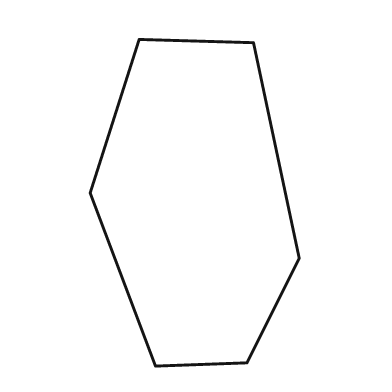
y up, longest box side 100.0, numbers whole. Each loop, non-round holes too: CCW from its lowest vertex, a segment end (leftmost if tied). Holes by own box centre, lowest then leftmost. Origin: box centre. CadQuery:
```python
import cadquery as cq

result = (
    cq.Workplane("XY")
    .moveTo(-12.0, -50.0)
    .lineTo(16.0, -49.0)
    .lineTo(32.0, -17.0)
    .lineTo(18.0, 49.0)
    .lineTo(-17.0, 50.0)
    .lineTo(-32.0, 3.0)
    .close()
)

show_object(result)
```